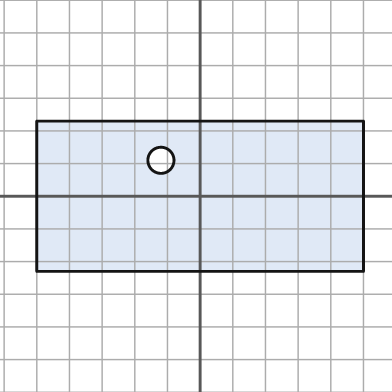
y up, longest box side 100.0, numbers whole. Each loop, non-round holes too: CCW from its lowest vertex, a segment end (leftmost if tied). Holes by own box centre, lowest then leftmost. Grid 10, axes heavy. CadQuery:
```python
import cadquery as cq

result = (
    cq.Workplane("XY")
    .moveTo(-50.0, -23.0)
    .lineTo(50.0, -23.0)
    .lineTo(50.0, 23.0)
    .lineTo(-50.0, 23.0)
    .close()
    .moveTo(-12.0, 11.0)
    .circle(4.0)
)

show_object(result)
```